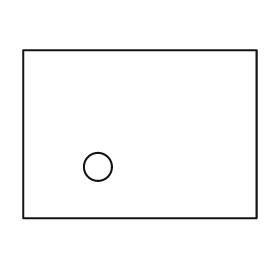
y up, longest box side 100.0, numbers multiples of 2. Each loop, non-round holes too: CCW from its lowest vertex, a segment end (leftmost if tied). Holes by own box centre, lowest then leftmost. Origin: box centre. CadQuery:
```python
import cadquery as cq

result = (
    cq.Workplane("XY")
    .moveTo(-50.0, -36.0)
    .lineTo(50.0, -36.0)
    .lineTo(50.0, 36.0)
    .lineTo(-50.0, 36.0)
    .close()
    .moveTo(-18.0, -14.0)
    .circle(6.0)
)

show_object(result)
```